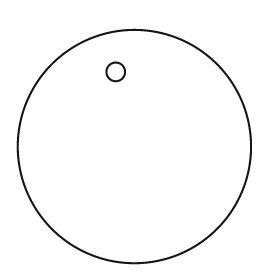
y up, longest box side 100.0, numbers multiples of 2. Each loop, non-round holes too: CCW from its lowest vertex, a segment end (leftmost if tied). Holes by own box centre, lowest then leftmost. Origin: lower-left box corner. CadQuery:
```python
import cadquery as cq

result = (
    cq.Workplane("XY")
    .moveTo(50.0, 50.0)
    .circle(50.0)
    .moveTo(42.0, 82.0)
    .circle(4.0)
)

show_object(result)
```